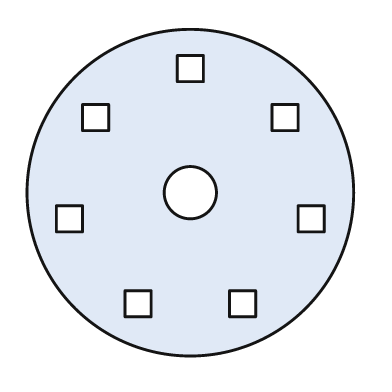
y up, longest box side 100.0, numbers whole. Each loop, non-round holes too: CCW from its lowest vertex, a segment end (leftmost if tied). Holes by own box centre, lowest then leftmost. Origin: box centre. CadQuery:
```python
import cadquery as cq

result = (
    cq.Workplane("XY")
    .moveTo(0.0, 0.0)
    .circle(50.0)
    .moveTo(-20.0, -38.0)
    .lineTo(-12.0, -38.0)
    .lineTo(-12.0, -30.0)
    .lineTo(-20.0, -30.0)
    .close()
    .moveTo(12.0, -38.0)
    .lineTo(20.0, -38.0)
    .lineTo(20.0, -30.0)
    .lineTo(12.0, -30.0)
    .close()
    .moveTo(-41.0, -12.0)
    .lineTo(-33.0, -12.0)
    .lineTo(-33.0, -4.0)
    .lineTo(-41.0, -4.0)
    .close()
    .moveTo(33.0, -12.0)
    .lineTo(41.0, -12.0)
    .lineTo(41.0, -4.0)
    .lineTo(33.0, -4.0)
    .close()
    .moveTo(0.0, 0.0)
    .circle(8.0)
    .moveTo(-33.0, 19.0)
    .lineTo(-25.0, 19.0)
    .lineTo(-25.0, 27.0)
    .lineTo(-33.0, 27.0)
    .close()
    .moveTo(25.0, 19.0)
    .lineTo(33.0, 19.0)
    .lineTo(33.0, 27.0)
    .lineTo(25.0, 27.0)
    .close()
    .moveTo(-4.0, 34.0)
    .lineTo(4.0, 34.0)
    .lineTo(4.0, 42.0)
    .lineTo(-4.0, 42.0)
    .close()
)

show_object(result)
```